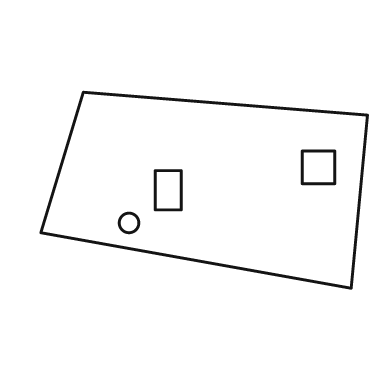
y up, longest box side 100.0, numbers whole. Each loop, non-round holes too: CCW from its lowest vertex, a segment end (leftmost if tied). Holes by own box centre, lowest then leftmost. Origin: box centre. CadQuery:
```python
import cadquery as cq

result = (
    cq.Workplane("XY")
    .moveTo(45.0, -30.0)
    .lineTo(50.0, 23.0)
    .lineTo(-37.0, 30.0)
    .lineTo(-50.0, -13.0)
    .close()
    .moveTo(-23.0, -10.0)
    .circle(3.0)
    .moveTo(-15.0, -6.0)
    .lineTo(-7.0, -6.0)
    .lineTo(-7.0, 6.0)
    .lineTo(-15.0, 6.0)
    .close()
    .moveTo(30.0, 2.0)
    .lineTo(40.0, 2.0)
    .lineTo(40.0, 12.0)
    .lineTo(30.0, 12.0)
    .close()
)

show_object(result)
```